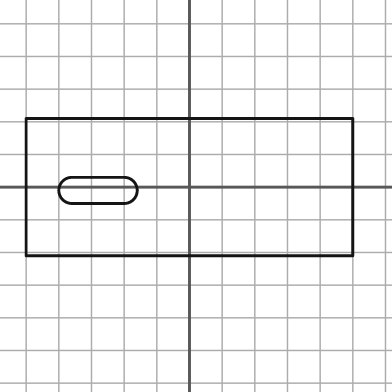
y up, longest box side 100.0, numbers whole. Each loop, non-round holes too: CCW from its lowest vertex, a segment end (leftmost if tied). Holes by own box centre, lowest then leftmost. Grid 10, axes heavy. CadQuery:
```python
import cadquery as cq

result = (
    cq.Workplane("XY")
    .moveTo(-50.0, -21.0)
    .lineTo(50.0, -21.0)
    .lineTo(50.0, 21.0)
    .lineTo(-50.0, 21.0)
    .close()
    .moveTo(-36.0, -5.0)
    .lineTo(-20.0, -5.0)
    .threePointArc((-16.0, -1.0), (-20.0, 3.0))
    .lineTo(-36.0, 3.0)
    .threePointArc((-40.0, -1.0), (-36.0, -5.0))
    .close()
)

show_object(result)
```